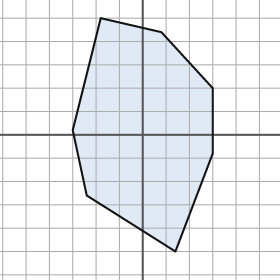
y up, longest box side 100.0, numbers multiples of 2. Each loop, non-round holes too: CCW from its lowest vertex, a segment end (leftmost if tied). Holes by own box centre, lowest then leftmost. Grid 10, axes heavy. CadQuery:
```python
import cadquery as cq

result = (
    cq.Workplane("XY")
    .moveTo(14.0, -50.0)
    .lineTo(30.0, -8.0)
    .lineTo(30.0, 20.0)
    .lineTo(8.0, 44.0)
    .lineTo(-18.0, 50.0)
    .lineTo(-30.0, 2.0)
    .lineTo(-24.0, -26.0)
    .close()
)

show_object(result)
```